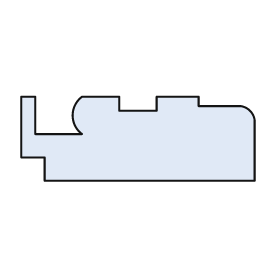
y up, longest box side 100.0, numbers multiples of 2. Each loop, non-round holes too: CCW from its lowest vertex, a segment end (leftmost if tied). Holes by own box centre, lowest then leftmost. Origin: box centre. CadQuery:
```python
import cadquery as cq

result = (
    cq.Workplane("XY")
    .moveTo(-40.0, -18.0)
    .lineTo(50.0, -18.0)
    .lineTo(50.0, 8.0)
    .threePointArc((48.0, 12.0), (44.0, 14.0))
    .lineTo(26.0, 14.0)
    .lineTo(26.0, 18.0)
    .lineTo(8.0, 18.0)
    .lineTo(8.0, 12.0)
    .lineTo(-8.0, 12.0)
    .lineTo(-8.0, 18.0)
    .lineTo(-24.0, 18.0)
    .threePointArc((-28.0, 10.0), (-24.0, 2.0))
    .lineTo(-44.0, 2.0)
    .lineTo(-44.0, 18.0)
    .lineTo(-50.0, 18.0)
    .lineTo(-50.0, -8.0)
    .lineTo(-40.0, -8.0)
    .close()
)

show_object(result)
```